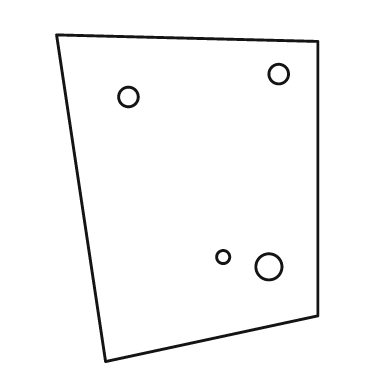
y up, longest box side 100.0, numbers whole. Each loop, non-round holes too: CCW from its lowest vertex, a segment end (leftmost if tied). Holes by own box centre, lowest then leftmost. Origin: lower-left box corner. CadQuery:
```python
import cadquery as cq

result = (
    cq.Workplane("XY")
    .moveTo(15.0, 0.0)
    .lineTo(80.0, 14.0)
    .lineTo(80.0, 98.0)
    .lineTo(0.0, 100.0)
    .close()
    .moveTo(65.0, 29.0)
    .circle(4.0)
    .moveTo(51.0, 32.0)
    .circle(2.0)
    .moveTo(22.0, 81.0)
    .circle(3.0)
    .moveTo(68.0, 88.0)
    .circle(3.0)
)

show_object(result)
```